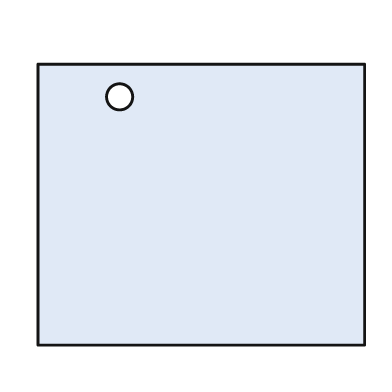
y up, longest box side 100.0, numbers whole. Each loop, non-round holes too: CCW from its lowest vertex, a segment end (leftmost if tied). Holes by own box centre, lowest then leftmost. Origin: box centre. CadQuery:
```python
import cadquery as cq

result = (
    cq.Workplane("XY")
    .moveTo(-50.0, -43.0)
    .lineTo(50.0, -43.0)
    .lineTo(50.0, 43.0)
    .lineTo(-50.0, 43.0)
    .close()
    .moveTo(-25.0, 33.0)
    .circle(4.0)
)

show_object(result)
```